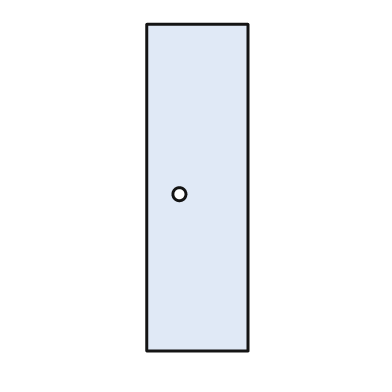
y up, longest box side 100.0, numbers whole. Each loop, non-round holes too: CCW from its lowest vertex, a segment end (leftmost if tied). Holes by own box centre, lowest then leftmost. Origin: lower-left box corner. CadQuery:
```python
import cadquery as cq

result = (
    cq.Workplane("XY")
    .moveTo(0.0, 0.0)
    .lineTo(31.0, 0.0)
    .lineTo(31.0, 100.0)
    .lineTo(0.0, 100.0)
    .close()
    .moveTo(10.0, 48.0)
    .circle(2.0)
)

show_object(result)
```